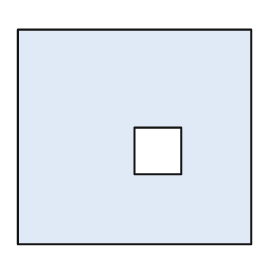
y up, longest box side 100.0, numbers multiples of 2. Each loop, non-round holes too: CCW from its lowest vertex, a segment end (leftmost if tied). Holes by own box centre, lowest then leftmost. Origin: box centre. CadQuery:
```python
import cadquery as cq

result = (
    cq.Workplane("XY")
    .moveTo(-50.0, -46.0)
    .lineTo(50.0, -46.0)
    .lineTo(50.0, 46.0)
    .lineTo(-50.0, 46.0)
    .close()
    .moveTo(0.0, -16.0)
    .lineTo(20.0, -16.0)
    .lineTo(20.0, 4.0)
    .lineTo(0.0, 4.0)
    .close()
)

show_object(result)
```